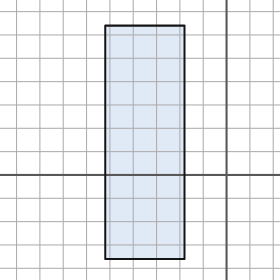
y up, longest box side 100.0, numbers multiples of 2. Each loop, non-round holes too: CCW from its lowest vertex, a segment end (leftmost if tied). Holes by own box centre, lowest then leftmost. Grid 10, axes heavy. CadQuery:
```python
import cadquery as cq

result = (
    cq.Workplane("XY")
    .moveTo(-52.0, -36.0)
    .lineTo(-18.0, -36.0)
    .lineTo(-18.0, 64.0)
    .lineTo(-52.0, 64.0)
    .close()
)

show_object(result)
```